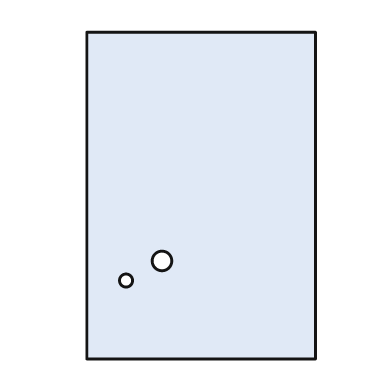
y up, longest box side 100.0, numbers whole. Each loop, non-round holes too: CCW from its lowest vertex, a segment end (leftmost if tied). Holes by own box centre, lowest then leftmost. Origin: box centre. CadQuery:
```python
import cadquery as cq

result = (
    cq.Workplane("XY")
    .moveTo(-35.0, -50.0)
    .lineTo(35.0, -50.0)
    .lineTo(35.0, 50.0)
    .lineTo(-35.0, 50.0)
    .close()
    .moveTo(-23.0, -26.0)
    .circle(2.0)
    .moveTo(-12.0, -20.0)
    .circle(3.0)
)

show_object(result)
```